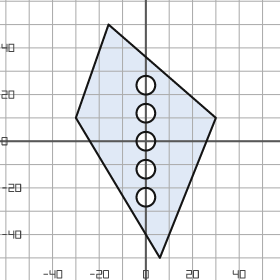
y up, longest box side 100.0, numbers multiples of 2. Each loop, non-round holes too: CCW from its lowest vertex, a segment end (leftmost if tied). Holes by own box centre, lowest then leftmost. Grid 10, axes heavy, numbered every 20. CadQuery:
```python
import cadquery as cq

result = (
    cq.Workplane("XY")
    .moveTo(6.0, -50.0)
    .lineTo(30.0, 10.0)
    .lineTo(-16.0, 50.0)
    .lineTo(-30.0, 10.0)
    .close()
    .moveTo(0.0, -24.0)
    .circle(4.0)
    .moveTo(0.0, -12.0)
    .circle(4.0)
    .moveTo(0.0, 0.0)
    .circle(4.0)
    .moveTo(0.0, 12.0)
    .circle(4.0)
    .moveTo(0.0, 24.0)
    .circle(4.0)
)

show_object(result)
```